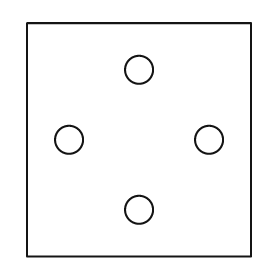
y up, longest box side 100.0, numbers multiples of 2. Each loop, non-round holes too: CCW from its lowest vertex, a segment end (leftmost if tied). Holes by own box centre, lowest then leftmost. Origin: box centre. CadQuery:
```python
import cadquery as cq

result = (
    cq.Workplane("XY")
    .moveTo(-48.0, -50.0)
    .lineTo(48.0, -50.0)
    .lineTo(48.0, 50.0)
    .lineTo(-48.0, 50.0)
    .close()
    .moveTo(0.0, -30.0)
    .circle(6.0)
    .moveTo(-30.0, 0.0)
    .circle(6.0)
    .moveTo(30.0, 0.0)
    .circle(6.0)
    .moveTo(0.0, 30.0)
    .circle(6.0)
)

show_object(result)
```